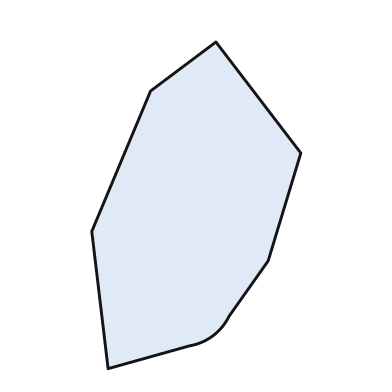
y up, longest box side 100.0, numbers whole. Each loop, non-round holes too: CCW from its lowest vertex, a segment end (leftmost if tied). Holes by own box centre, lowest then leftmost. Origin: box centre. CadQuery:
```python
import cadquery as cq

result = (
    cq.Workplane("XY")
    .moveTo(-27.0, -50.0)
    .lineTo(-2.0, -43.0)
    .threePointArc((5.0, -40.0), (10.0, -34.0))
    .lineTo(22.0, -17.0)
    .lineTo(32.0, 16.0)
    .lineTo(6.0, 50.0)
    .lineTo(-14.0, 35.0)
    .lineTo(-32.0, -8.0)
    .close()
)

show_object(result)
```